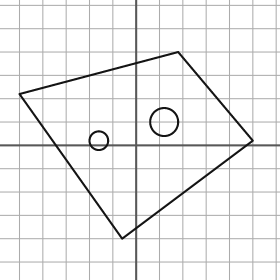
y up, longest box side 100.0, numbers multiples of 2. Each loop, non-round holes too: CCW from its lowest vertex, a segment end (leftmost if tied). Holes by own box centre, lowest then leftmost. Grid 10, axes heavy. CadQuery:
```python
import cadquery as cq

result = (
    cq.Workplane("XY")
    .moveTo(-6.0, -40.0)
    .lineTo(50.0, 2.0)
    .lineTo(18.0, 40.0)
    .lineTo(-50.0, 22.0)
    .close()
    .moveTo(-16.0, 2.0)
    .circle(4.0)
    .moveTo(12.0, 10.0)
    .circle(6.0)
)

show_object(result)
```